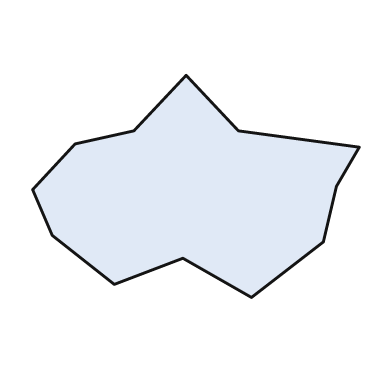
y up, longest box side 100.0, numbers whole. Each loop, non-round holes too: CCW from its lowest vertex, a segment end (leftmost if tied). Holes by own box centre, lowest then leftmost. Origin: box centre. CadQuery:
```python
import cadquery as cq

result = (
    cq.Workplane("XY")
    .moveTo(17.0, -34.0)
    .lineTo(39.0, -17.0)
    .lineTo(43.0, 0.0)
    .lineTo(50.0, 12.0)
    .lineTo(13.0, 17.0)
    .lineTo(-3.0, 34.0)
    .lineTo(-19.0, 17.0)
    .lineTo(-37.0, 13.0)
    .lineTo(-50.0, -1.0)
    .lineTo(-44.0, -15.0)
    .lineTo(-25.0, -30.0)
    .lineTo(-4.0, -22.0)
    .close()
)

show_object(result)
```